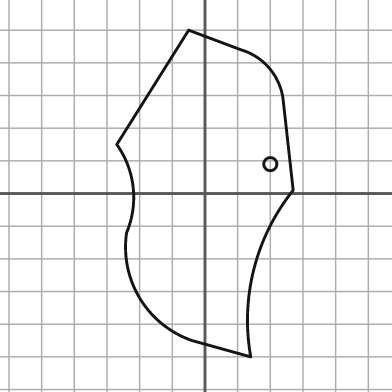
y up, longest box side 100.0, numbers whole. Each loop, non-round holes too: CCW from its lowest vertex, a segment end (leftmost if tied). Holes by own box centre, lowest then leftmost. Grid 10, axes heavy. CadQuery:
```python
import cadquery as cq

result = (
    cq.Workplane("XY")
    .moveTo(14.0, -50.0)
    .threePointArc((15.0, -23.0), (27.0, 1.0))
    .lineTo(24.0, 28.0)
    .threePointArc((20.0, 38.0), (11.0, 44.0))
    .lineTo(-5.0, 50.0)
    .lineTo(-27.0, 15.0)
    .threePointArc((-22.0, 2.0), (-24.0, -12.0))
    .threePointArc((-20.0, -32.0), (-4.0, -45.0))
    .close()
    .moveTo(20.0, 9.0)
    .circle(2.0)
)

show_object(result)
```